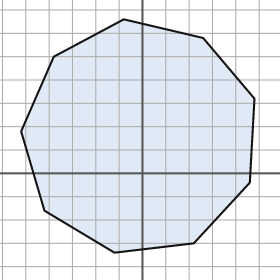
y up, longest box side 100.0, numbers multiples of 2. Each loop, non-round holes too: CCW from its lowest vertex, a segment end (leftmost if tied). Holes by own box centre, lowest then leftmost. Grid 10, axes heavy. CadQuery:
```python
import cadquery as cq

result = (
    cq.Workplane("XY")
    .moveTo(-12.0, -34.0)
    .lineTo(22.0, -30.0)
    .lineTo(46.0, -4.0)
    .lineTo(48.0, 32.0)
    .lineTo(26.0, 58.0)
    .lineTo(-8.0, 66.0)
    .lineTo(-38.0, 50.0)
    .lineTo(-52.0, 18.0)
    .lineTo(-42.0, -16.0)
    .close()
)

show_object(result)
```